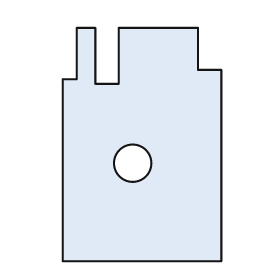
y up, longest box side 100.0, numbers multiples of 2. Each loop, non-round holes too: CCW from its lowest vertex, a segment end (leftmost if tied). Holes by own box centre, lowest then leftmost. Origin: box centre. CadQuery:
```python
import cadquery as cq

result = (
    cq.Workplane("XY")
    .moveTo(-34.0, -50.0)
    .lineTo(34.0, -50.0)
    .lineTo(34.0, 32.0)
    .lineTo(24.0, 32.0)
    .lineTo(24.0, 50.0)
    .lineTo(-10.0, 50.0)
    .lineTo(-10.0, 26.0)
    .lineTo(-20.0, 26.0)
    .lineTo(-20.0, 50.0)
    .lineTo(-28.0, 50.0)
    .lineTo(-28.0, 28.0)
    .lineTo(-34.0, 28.0)
    .close()
    .moveTo(-4.0, -8.0)
    .circle(8.0)
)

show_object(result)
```